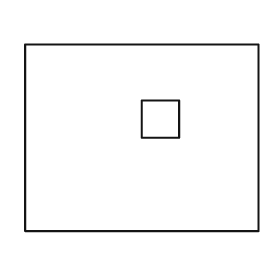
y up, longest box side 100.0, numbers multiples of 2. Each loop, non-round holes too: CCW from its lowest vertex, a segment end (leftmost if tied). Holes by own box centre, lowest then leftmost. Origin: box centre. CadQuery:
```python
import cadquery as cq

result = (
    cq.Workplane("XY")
    .moveTo(-50.0, -40.0)
    .lineTo(50.0, -40.0)
    .lineTo(50.0, 40.0)
    .lineTo(-50.0, 40.0)
    .close()
    .moveTo(0.0, 0.0)
    .lineTo(16.0, 0.0)
    .lineTo(16.0, 16.0)
    .lineTo(0.0, 16.0)
    .close()
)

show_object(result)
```